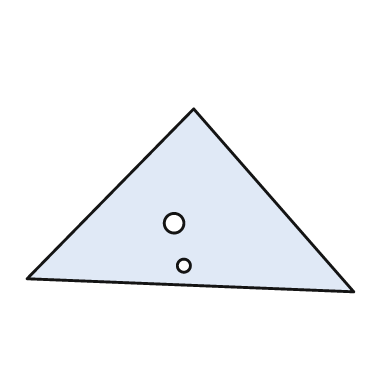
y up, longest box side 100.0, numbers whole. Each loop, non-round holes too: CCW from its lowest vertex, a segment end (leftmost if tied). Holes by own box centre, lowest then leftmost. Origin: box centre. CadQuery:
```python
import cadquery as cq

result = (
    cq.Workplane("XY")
    .moveTo(50.0, -28.0)
    .lineTo(1.0, 28.0)
    .lineTo(-50.0, -24.0)
    .close()
    .moveTo(-2.0, -20.0)
    .circle(2.0)
    .moveTo(-5.0, -7.0)
    .circle(3.0)
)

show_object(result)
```